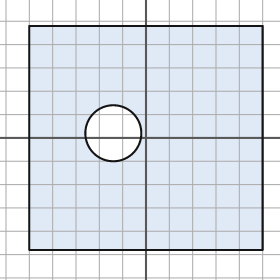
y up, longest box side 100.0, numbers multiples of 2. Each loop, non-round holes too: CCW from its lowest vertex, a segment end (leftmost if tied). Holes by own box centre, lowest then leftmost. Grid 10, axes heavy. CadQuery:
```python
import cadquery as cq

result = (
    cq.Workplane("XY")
    .moveTo(-50.0, -48.0)
    .lineTo(50.0, -48.0)
    .lineTo(50.0, 48.0)
    .lineTo(-50.0, 48.0)
    .close()
    .moveTo(-14.0, 2.0)
    .circle(12.0)
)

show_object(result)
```